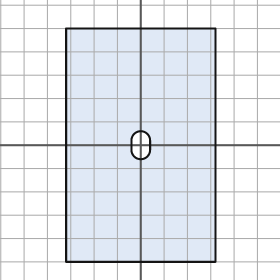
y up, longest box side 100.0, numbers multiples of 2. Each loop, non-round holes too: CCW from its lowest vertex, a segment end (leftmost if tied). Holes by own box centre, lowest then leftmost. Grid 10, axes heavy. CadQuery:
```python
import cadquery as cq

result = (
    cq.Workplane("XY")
    .moveTo(-32.0, -50.0)
    .lineTo(32.0, -50.0)
    .lineTo(32.0, 50.0)
    .lineTo(-32.0, 50.0)
    .close()
    .moveTo(-4.0, -2.0)
    .threePointArc((0.0, -6.0), (4.0, -2.0))
    .lineTo(4.0, 2.0)
    .threePointArc((0.0, 6.0), (-4.0, 2.0))
    .close()
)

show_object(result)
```